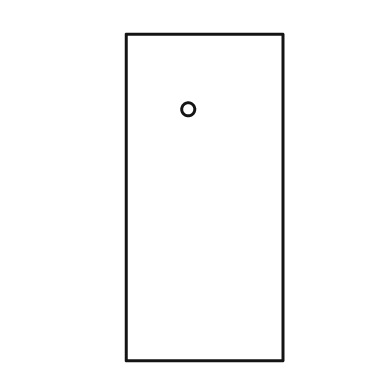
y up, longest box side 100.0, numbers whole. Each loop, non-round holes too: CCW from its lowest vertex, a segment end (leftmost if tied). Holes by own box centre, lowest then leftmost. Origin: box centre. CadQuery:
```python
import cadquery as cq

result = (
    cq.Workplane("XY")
    .moveTo(-24.0, -50.0)
    .lineTo(24.0, -50.0)
    .lineTo(24.0, 50.0)
    .lineTo(-24.0, 50.0)
    .close()
    .moveTo(-5.0, 27.0)
    .circle(2.0)
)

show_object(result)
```